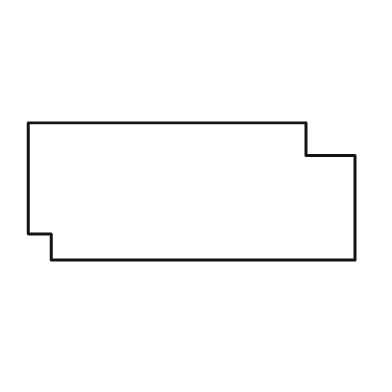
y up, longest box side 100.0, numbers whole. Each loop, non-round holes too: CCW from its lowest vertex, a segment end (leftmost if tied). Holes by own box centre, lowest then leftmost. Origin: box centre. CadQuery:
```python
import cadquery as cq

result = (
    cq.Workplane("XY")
    .moveTo(-43.0, -21.0)
    .lineTo(50.0, -21.0)
    .lineTo(50.0, 11.0)
    .lineTo(35.0, 11.0)
    .lineTo(35.0, 21.0)
    .lineTo(-50.0, 21.0)
    .lineTo(-50.0, -13.0)
    .lineTo(-43.0, -13.0)
    .close()
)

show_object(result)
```